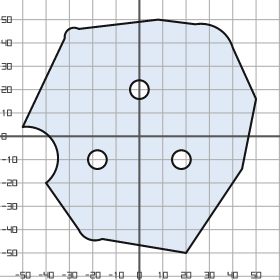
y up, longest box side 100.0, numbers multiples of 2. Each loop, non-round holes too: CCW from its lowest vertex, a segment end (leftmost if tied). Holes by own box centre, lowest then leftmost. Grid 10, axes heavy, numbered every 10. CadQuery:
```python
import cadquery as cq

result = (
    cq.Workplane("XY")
    .moveTo(20.0, -50.0)
    .lineTo(44.0, -14.0)
    .lineTo(50.0, 16.0)
    .lineTo(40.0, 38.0)
    .threePointArc((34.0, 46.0), (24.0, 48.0))
    .lineTo(8.0, 50.0)
    .lineTo(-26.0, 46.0)
    .threePointArc((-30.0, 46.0), (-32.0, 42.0))
    .lineTo(-50.0, 4.0)
    .threePointArc((-36.0, -4.0), (-40.0, -20.0))
    .lineTo(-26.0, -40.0)
    .threePointArc((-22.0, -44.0), (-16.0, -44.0))
    .close()
    .moveTo(-18.0, -10.0)
    .circle(4.0)
    .moveTo(18.0, -10.0)
    .circle(4.0)
    .moveTo(0.0, 20.0)
    .circle(4.0)
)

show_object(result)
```